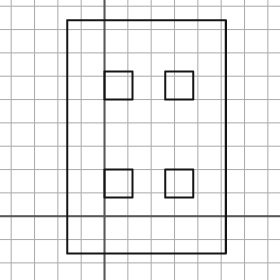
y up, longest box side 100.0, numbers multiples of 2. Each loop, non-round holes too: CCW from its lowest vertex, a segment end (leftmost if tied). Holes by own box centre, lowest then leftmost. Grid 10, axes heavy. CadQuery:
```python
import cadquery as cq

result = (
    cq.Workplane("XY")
    .moveTo(-16.0, -16.0)
    .lineTo(52.0, -16.0)
    .lineTo(52.0, 84.0)
    .lineTo(-16.0, 84.0)
    .close()
    .moveTo(0.0, 8.0)
    .lineTo(12.0, 8.0)
    .lineTo(12.0, 20.0)
    .lineTo(0.0, 20.0)
    .close()
    .moveTo(26.0, 8.0)
    .lineTo(38.0, 8.0)
    .lineTo(38.0, 20.0)
    .lineTo(26.0, 20.0)
    .close()
    .moveTo(0.0, 50.0)
    .lineTo(12.0, 50.0)
    .lineTo(12.0, 62.0)
    .lineTo(0.0, 62.0)
    .close()
    .moveTo(26.0, 50.0)
    .lineTo(38.0, 50.0)
    .lineTo(38.0, 62.0)
    .lineTo(26.0, 62.0)
    .close()
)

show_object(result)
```